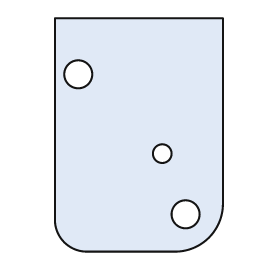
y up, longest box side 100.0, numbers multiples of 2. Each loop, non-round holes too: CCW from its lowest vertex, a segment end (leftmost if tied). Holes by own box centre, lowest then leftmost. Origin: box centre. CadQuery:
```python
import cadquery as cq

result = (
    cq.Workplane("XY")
    .moveTo(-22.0, -50.0)
    .lineTo(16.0, -50.0)
    .threePointArc((30.0, -44.0), (36.0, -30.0))
    .lineTo(36.0, 50.0)
    .lineTo(-36.0, 50.0)
    .lineTo(-36.0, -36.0)
    .threePointArc((-32.0, -46.0), (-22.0, -50.0))
    .close()
    .moveTo(20.0, -34.0)
    .circle(6.0)
    .moveTo(10.0, -8.0)
    .circle(4.0)
    .moveTo(-26.0, 26.0)
    .circle(6.0)
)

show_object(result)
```